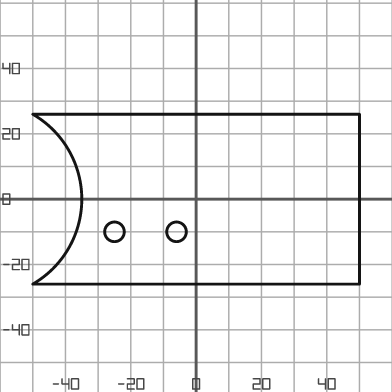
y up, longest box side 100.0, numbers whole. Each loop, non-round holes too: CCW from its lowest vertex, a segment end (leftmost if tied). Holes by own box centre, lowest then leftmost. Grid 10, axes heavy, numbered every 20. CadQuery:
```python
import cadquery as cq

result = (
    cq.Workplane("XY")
    .moveTo(-50.0, -26.0)
    .lineTo(50.0, -26.0)
    .lineTo(50.0, 26.0)
    .lineTo(-50.0, 26.0)
    .threePointArc((-35.0, 0.0), (-50.0, -26.0))
    .close()
    .moveTo(-25.0, -10.0)
    .circle(3.0)
    .moveTo(-6.0, -10.0)
    .circle(3.0)
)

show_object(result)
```